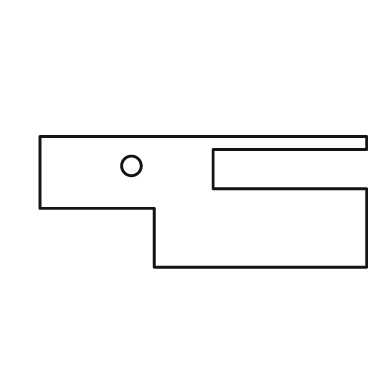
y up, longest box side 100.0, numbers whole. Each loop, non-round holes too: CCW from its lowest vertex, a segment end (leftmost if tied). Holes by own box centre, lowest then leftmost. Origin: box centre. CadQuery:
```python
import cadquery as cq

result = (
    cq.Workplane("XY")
    .moveTo(-15.0, -20.0)
    .lineTo(50.0, -20.0)
    .lineTo(50.0, 4.0)
    .lineTo(3.0, 4.0)
    .lineTo(3.0, 16.0)
    .lineTo(50.0, 16.0)
    .lineTo(50.0, 20.0)
    .lineTo(-50.0, 20.0)
    .lineTo(-50.0, -2.0)
    .lineTo(-15.0, -2.0)
    .close()
    .moveTo(-22.0, 11.0)
    .circle(3.0)
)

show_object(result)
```